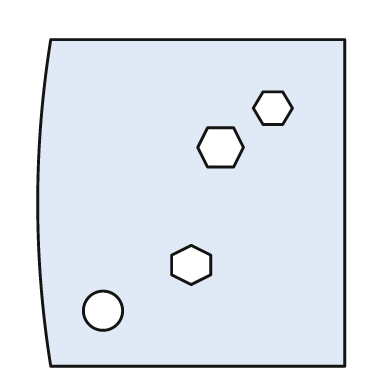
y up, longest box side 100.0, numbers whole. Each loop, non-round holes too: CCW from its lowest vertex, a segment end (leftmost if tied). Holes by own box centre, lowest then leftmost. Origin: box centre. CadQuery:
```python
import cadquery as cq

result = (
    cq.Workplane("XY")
    .moveTo(-43.0, -50.0)
    .lineTo(47.0, -50.0)
    .lineTo(47.0, 50.0)
    .lineTo(-43.0, 50.0)
    .threePointArc((-47.0, 0.0), (-43.0, -50.0))
    .close()
    .moveTo(-27.0, -33.0)
    .circle(6.0)
    .moveTo(0.0, -25.0)
    .lineTo(6.0, -22.0)
    .lineTo(6.0, -16.0)
    .lineTo(0.0, -13.0)
    .lineTo(-6.0, -16.0)
    .lineTo(-6.0, -22.0)
    .close()
    .moveTo(5.0, 11.0)
    .lineTo(13.0, 11.0)
    .lineTo(16.0, 17.0)
    .lineTo(13.0, 23.0)
    .lineTo(5.0, 23.0)
    .lineTo(2.0, 17.0)
    .close()
    .moveTo(22.0, 24.0)
    .lineTo(28.0, 24.0)
    .lineTo(31.0, 29.0)
    .lineTo(28.0, 34.0)
    .lineTo(22.0, 34.0)
    .lineTo(19.0, 29.0)
    .close()
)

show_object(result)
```